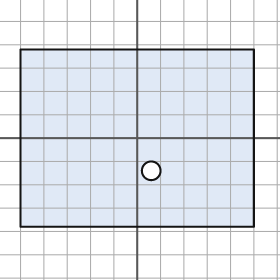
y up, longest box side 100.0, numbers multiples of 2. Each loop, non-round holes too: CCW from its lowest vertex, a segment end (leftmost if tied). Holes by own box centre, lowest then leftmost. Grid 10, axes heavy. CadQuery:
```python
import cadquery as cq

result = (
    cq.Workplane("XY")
    .moveTo(-50.0, -38.0)
    .lineTo(50.0, -38.0)
    .lineTo(50.0, 38.0)
    .lineTo(-50.0, 38.0)
    .close()
    .moveTo(6.0, -14.0)
    .circle(4.0)
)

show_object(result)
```